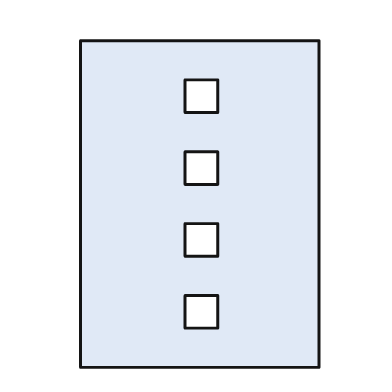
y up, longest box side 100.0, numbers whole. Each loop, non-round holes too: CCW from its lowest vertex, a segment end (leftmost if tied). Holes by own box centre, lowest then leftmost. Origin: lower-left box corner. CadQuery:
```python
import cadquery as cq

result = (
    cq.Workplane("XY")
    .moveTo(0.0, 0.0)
    .lineTo(73.0, 0.0)
    .lineTo(73.0, 100.0)
    .lineTo(0.0, 100.0)
    .close()
    .moveTo(32.0, 12.0)
    .lineTo(42.0, 12.0)
    .lineTo(42.0, 22.0)
    .lineTo(32.0, 22.0)
    .close()
    .moveTo(32.0, 34.0)
    .lineTo(42.0, 34.0)
    .lineTo(42.0, 44.0)
    .lineTo(32.0, 44.0)
    .close()
    .moveTo(32.0, 56.0)
    .lineTo(42.0, 56.0)
    .lineTo(42.0, 66.0)
    .lineTo(32.0, 66.0)
    .close()
    .moveTo(32.0, 78.0)
    .lineTo(42.0, 78.0)
    .lineTo(42.0, 88.0)
    .lineTo(32.0, 88.0)
    .close()
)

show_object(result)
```